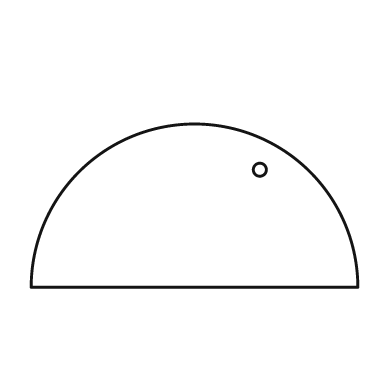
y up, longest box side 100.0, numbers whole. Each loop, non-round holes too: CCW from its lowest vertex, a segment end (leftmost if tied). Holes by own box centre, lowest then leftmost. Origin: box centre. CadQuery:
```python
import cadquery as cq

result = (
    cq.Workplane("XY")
    .moveTo(-50.0, -25.0)
    .lineTo(50.0, -25.0)
    .threePointArc((0.0, 25.0), (-50.0, -25.0))
    .close()
    .moveTo(20.0, 11.0)
    .circle(2.0)
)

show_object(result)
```